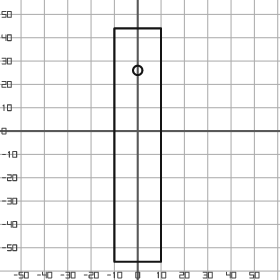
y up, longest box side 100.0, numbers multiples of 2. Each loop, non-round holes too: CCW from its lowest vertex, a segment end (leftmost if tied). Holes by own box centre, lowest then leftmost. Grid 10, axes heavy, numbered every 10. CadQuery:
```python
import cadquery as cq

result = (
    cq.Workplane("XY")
    .moveTo(-10.0, -56.0)
    .lineTo(10.0, -56.0)
    .lineTo(10.0, 44.0)
    .lineTo(-10.0, 44.0)
    .close()
    .moveTo(0.0, 26.0)
    .circle(2.0)
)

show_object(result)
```